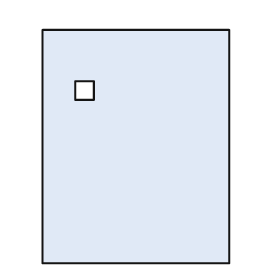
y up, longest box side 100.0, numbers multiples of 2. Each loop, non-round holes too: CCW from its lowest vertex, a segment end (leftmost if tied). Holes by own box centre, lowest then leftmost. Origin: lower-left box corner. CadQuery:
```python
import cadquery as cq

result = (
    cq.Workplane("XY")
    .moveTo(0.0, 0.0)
    .lineTo(80.0, 0.0)
    .lineTo(80.0, 100.0)
    .lineTo(0.0, 100.0)
    .close()
    .moveTo(14.0, 70.0)
    .lineTo(22.0, 70.0)
    .lineTo(22.0, 78.0)
    .lineTo(14.0, 78.0)
    .close()
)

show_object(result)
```